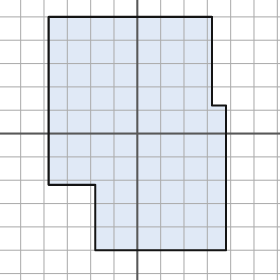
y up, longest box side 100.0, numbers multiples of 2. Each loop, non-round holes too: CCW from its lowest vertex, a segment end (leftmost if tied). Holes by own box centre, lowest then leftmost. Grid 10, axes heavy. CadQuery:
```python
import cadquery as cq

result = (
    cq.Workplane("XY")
    .moveTo(-18.0, -50.0)
    .lineTo(38.0, -50.0)
    .lineTo(38.0, 12.0)
    .lineTo(32.0, 12.0)
    .lineTo(32.0, 50.0)
    .lineTo(-38.0, 50.0)
    .lineTo(-38.0, -22.0)
    .lineTo(-18.0, -22.0)
    .close()
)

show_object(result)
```